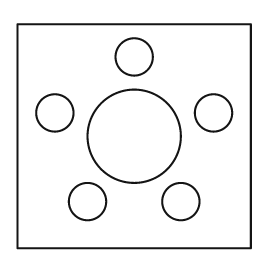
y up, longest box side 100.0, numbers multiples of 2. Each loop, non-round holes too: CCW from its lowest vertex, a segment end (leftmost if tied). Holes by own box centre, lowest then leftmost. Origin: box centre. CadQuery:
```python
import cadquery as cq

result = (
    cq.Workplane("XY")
    .moveTo(-50.0, -48.0)
    .lineTo(50.0, -48.0)
    .lineTo(50.0, 48.0)
    .lineTo(-50.0, 48.0)
    .close()
    .moveTo(-20.0, -28.0)
    .circle(8.0)
    .moveTo(20.0, -28.0)
    .circle(8.0)
    .moveTo(0.0, 0.0)
    .circle(20.0)
    .moveTo(-34.0, 10.0)
    .circle(8.0)
    .moveTo(34.0, 10.0)
    .circle(8.0)
    .moveTo(0.0, 34.0)
    .circle(8.0)
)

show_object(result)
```